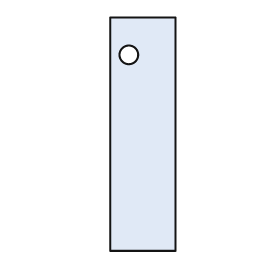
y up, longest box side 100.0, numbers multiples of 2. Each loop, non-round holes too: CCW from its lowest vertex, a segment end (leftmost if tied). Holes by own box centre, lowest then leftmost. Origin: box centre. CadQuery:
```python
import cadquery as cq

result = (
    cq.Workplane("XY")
    .moveTo(-14.0, -50.0)
    .lineTo(14.0, -50.0)
    .lineTo(14.0, 50.0)
    .lineTo(-14.0, 50.0)
    .close()
    .moveTo(-6.0, 34.0)
    .circle(4.0)
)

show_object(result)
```